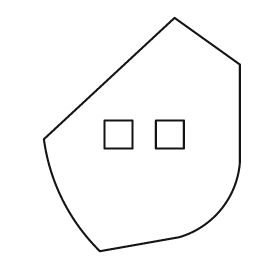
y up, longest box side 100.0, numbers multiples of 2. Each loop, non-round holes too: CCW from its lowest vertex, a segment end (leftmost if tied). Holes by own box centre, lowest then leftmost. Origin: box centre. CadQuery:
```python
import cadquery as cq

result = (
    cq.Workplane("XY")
    .moveTo(-18.0, -50.0)
    .lineTo(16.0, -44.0)
    .threePointArc((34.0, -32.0), (42.0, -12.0))
    .lineTo(42.0, 30.0)
    .lineTo(14.0, 50.0)
    .lineTo(-42.0, -2.0)
    .threePointArc((-34.0, -28.0), (-18.0, -50.0))
    .close()
    .moveTo(-16.0, -6.0)
    .lineTo(-4.0, -6.0)
    .lineTo(-4.0, 6.0)
    .lineTo(-16.0, 6.0)
    .close()
    .moveTo(6.0, -6.0)
    .lineTo(18.0, -6.0)
    .lineTo(18.0, 6.0)
    .lineTo(6.0, 6.0)
    .close()
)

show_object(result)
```